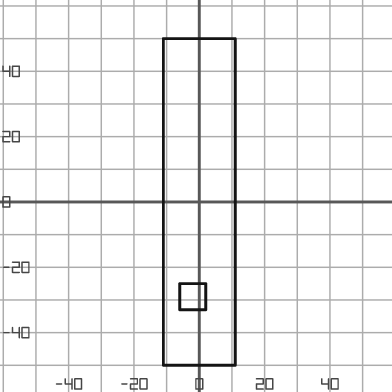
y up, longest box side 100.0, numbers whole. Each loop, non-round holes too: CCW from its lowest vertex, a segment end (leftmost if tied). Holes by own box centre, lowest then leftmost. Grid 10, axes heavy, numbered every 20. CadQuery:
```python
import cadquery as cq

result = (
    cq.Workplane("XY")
    .moveTo(-11.0, -50.0)
    .lineTo(11.0, -50.0)
    .lineTo(11.0, 50.0)
    .lineTo(-11.0, 50.0)
    .close()
    .moveTo(-6.0, -33.0)
    .lineTo(2.0, -33.0)
    .lineTo(2.0, -25.0)
    .lineTo(-6.0, -25.0)
    .close()
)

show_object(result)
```